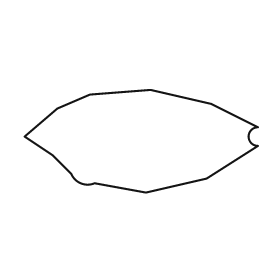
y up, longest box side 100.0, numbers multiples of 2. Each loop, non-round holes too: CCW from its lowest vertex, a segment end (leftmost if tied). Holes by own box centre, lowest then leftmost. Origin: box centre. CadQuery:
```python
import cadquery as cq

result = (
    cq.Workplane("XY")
    .moveTo(2.0, -22.0)
    .lineTo(28.0, -16.0)
    .lineTo(50.0, -2.0)
    .threePointArc((46.0, 2.0), (50.0, 6.0))
    .lineTo(30.0, 16.0)
    .lineTo(4.0, 22.0)
    .lineTo(-22.0, 20.0)
    .lineTo(-36.0, 14.0)
    .lineTo(-50.0, 2.0)
    .lineTo(-38.0, -6.0)
    .lineTo(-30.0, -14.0)
    .threePointArc((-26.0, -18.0), (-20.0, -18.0))
    .close()
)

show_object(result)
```